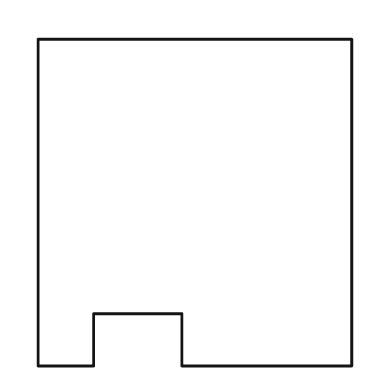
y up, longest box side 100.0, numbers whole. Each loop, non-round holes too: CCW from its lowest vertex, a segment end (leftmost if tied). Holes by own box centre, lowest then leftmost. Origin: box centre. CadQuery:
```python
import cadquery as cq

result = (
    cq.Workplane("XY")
    .moveTo(-48.0, -50.0)
    .lineTo(-31.0, -50.0)
    .lineTo(-31.0, -34.0)
    .lineTo(-4.0, -34.0)
    .lineTo(-4.0, -50.0)
    .lineTo(48.0, -50.0)
    .lineTo(48.0, 50.0)
    .lineTo(-48.0, 50.0)
    .close()
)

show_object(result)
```